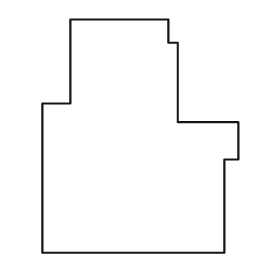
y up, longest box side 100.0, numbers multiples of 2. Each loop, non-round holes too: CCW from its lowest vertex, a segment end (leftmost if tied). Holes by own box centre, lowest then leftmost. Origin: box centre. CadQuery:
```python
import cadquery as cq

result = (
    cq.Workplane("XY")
    .moveTo(-42.0, -50.0)
    .lineTo(36.0, -50.0)
    .lineTo(36.0, -10.0)
    .lineTo(42.0, -10.0)
    .lineTo(42.0, 6.0)
    .lineTo(16.0, 6.0)
    .lineTo(16.0, 40.0)
    .lineTo(12.0, 40.0)
    .lineTo(12.0, 50.0)
    .lineTo(-30.0, 50.0)
    .lineTo(-30.0, 14.0)
    .lineTo(-42.0, 14.0)
    .close()
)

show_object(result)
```